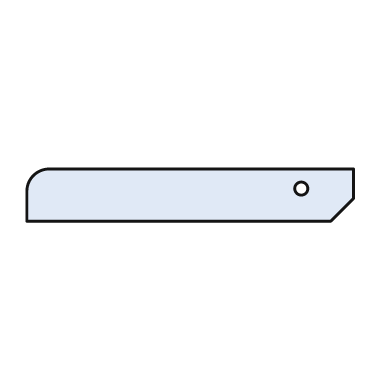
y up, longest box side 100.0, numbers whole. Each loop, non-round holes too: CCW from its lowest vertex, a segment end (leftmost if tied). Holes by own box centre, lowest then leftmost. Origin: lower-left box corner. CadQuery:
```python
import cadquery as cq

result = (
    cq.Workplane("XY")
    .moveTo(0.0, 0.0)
    .lineTo(93.0, 0.0)
    .lineTo(100.0, 7.0)
    .lineTo(100.0, 16.0)
    .lineTo(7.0, 16.0)
    .threePointArc((2.0, 14.0), (0.0, 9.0))
    .close()
    .moveTo(84.0, 10.0)
    .circle(2.0)
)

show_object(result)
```